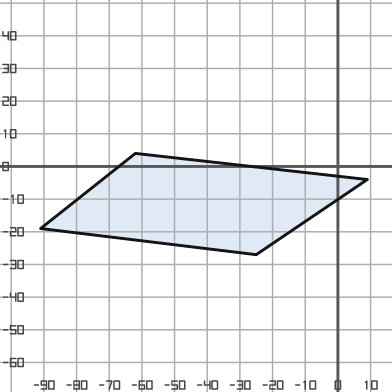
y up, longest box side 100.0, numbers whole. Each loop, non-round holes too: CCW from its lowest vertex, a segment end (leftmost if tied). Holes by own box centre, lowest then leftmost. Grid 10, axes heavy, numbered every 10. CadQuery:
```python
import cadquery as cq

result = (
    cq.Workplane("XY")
    .moveTo(-25.0, -27.0)
    .lineTo(9.0, -4.0)
    .lineTo(-62.0, 4.0)
    .lineTo(-91.0, -19.0)
    .close()
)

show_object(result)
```